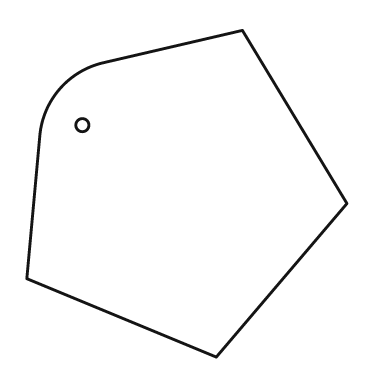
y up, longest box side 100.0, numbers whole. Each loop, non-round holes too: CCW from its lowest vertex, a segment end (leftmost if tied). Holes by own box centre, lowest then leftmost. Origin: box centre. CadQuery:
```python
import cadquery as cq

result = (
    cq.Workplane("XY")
    .moveTo(9.0, -50.0)
    .lineTo(49.0, -3.0)
    .lineTo(17.0, 50.0)
    .lineTo(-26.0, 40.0)
    .threePointArc((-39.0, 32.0), (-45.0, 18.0))
    .lineTo(-49.0, -26.0)
    .close()
    .moveTo(-32.0, 21.0)
    .circle(2.0)
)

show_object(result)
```